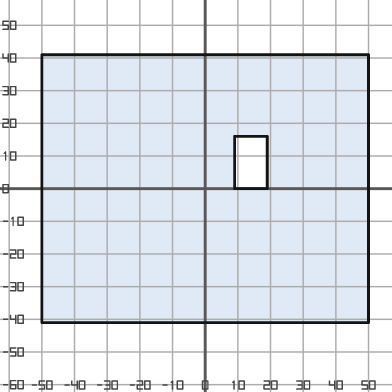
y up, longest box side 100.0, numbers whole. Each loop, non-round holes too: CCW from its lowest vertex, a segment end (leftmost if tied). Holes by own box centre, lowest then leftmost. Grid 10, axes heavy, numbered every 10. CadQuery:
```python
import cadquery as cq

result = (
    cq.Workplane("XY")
    .moveTo(-50.0, -41.0)
    .lineTo(50.0, -41.0)
    .lineTo(50.0, 41.0)
    .lineTo(-50.0, 41.0)
    .close()
    .moveTo(9.0, 0.0)
    .lineTo(19.0, 0.0)
    .lineTo(19.0, 16.0)
    .lineTo(9.0, 16.0)
    .close()
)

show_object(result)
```